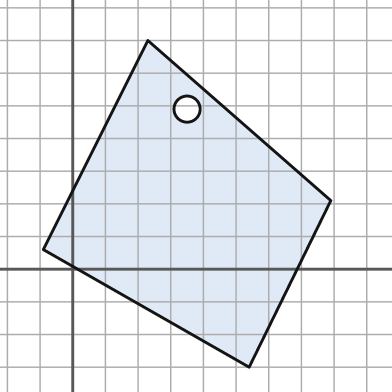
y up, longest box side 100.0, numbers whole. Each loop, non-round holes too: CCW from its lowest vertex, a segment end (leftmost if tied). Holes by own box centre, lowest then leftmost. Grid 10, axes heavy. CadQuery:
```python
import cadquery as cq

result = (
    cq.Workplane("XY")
    .moveTo(54.0, -30.0)
    .lineTo(79.0, 21.0)
    .lineTo(23.0, 70.0)
    .lineTo(-9.0, 6.0)
    .close()
    .moveTo(35.0, 49.0)
    .circle(4.0)
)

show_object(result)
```